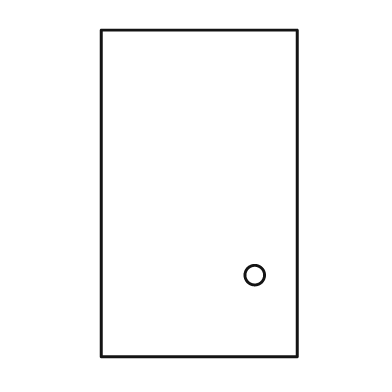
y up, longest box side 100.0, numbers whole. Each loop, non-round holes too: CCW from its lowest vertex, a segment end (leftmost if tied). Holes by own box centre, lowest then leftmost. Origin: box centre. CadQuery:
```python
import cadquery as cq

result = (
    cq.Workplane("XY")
    .moveTo(-30.0, -50.0)
    .lineTo(30.0, -50.0)
    .lineTo(30.0, 50.0)
    .lineTo(-30.0, 50.0)
    .close()
    .moveTo(17.0, -25.0)
    .circle(3.0)
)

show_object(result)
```